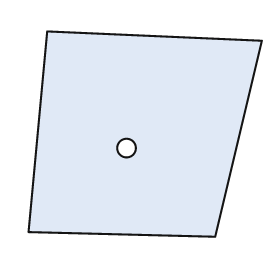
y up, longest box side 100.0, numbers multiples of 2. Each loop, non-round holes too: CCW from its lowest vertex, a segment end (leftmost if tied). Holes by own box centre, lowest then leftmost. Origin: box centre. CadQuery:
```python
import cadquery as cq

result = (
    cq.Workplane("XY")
    .moveTo(30.0, -44.0)
    .lineTo(50.0, 40.0)
    .lineTo(-42.0, 44.0)
    .lineTo(-50.0, -42.0)
    .close()
    .moveTo(-8.0, -6.0)
    .circle(4.0)
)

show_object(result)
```